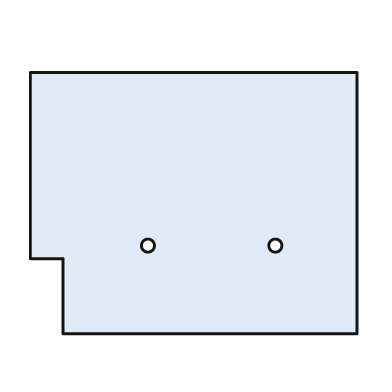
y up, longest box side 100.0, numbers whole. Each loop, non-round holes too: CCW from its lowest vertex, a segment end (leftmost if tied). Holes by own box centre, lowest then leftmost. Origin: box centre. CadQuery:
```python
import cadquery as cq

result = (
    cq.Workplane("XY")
    .moveTo(-40.0, -40.0)
    .lineTo(50.0, -40.0)
    .lineTo(50.0, 40.0)
    .lineTo(-50.0, 40.0)
    .lineTo(-50.0, -17.0)
    .lineTo(-40.0, -17.0)
    .close()
    .moveTo(-14.0, -13.0)
    .circle(2.0)
    .moveTo(25.0, -13.0)
    .circle(2.0)
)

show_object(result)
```